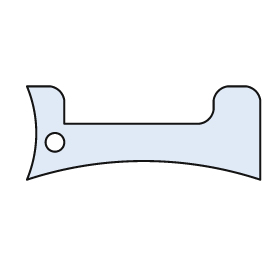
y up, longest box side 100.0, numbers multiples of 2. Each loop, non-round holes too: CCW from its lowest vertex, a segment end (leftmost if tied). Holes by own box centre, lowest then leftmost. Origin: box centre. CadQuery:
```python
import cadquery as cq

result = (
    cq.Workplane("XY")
    .moveTo(-50.0, -20.0)
    .threePointArc((0.0, -12.0), (50.0, -20.0))
    .lineTo(50.0, 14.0)
    .threePointArc((48.0, 18.0), (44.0, 20.0))
    .lineTo(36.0, 20.0)
    .threePointArc((32.0, 18.0), (30.0, 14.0))
    .lineTo(30.0, 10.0)
    .threePointArc((28.0, 6.0), (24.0, 4.0))
    .lineTo(-34.0, 4.0)
    .lineTo(-34.0, 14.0)
    .threePointArc((-36.0, 18.0), (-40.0, 20.0))
    .lineTo(-50.0, 20.0)
    .threePointArc((-46.0, 0.0), (-50.0, -20.0))
    .close()
    .moveTo(-38.0, -4.0)
    .circle(4.0)
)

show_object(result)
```